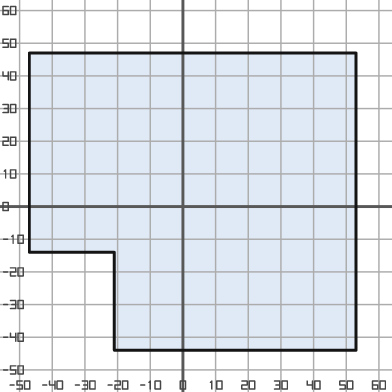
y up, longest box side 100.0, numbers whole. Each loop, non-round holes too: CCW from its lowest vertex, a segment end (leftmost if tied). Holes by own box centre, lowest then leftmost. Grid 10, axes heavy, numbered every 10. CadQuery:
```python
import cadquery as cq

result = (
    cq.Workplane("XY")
    .moveTo(-21.0, -44.0)
    .lineTo(53.0, -44.0)
    .lineTo(53.0, 47.0)
    .lineTo(-47.0, 47.0)
    .lineTo(-47.0, -14.0)
    .lineTo(-21.0, -14.0)
    .close()
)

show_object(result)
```